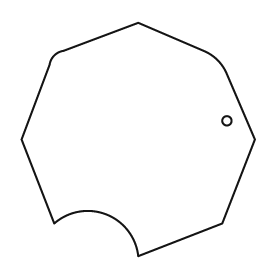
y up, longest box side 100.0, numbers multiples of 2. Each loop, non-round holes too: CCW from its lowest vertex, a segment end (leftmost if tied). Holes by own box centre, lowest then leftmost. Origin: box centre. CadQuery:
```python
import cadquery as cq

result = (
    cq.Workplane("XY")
    .moveTo(0.0, -50.0)
    .lineTo(36.0, -36.0)
    .lineTo(50.0, 0.0)
    .lineTo(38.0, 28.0)
    .threePointArc((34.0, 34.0), (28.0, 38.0))
    .lineTo(0.0, 50.0)
    .lineTo(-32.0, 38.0)
    .threePointArc((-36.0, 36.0), (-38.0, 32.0))
    .lineTo(-50.0, 0.0)
    .lineTo(-36.0, -36.0)
    .threePointArc((-14.0, -32.0), (0.0, -50.0))
    .close()
    .moveTo(38.0, 8.0)
    .circle(2.0)
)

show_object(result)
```